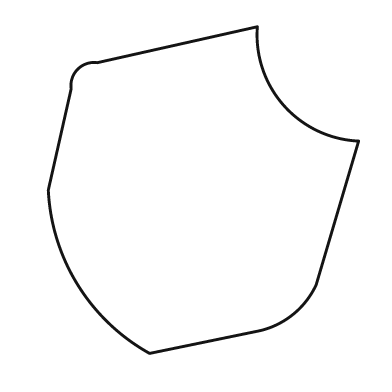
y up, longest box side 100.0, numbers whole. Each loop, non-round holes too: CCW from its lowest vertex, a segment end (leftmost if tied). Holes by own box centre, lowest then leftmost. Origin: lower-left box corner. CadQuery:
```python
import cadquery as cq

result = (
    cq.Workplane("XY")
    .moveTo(31.0, 0.0)
    .lineTo(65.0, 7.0)
    .threePointArc((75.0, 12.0), (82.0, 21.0))
    .lineTo(95.0, 65.0)
    .threePointArc((72.0, 76.0), (64.0, 100.0))
    .lineTo(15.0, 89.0)
    .threePointArc((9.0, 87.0), (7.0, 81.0))
    .lineTo(0.0, 50.0)
    .threePointArc((9.0, 21.0), (31.0, 0.0))
    .close()
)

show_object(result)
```